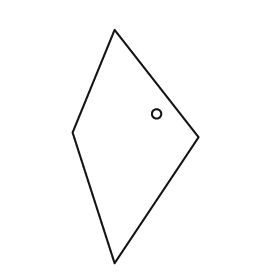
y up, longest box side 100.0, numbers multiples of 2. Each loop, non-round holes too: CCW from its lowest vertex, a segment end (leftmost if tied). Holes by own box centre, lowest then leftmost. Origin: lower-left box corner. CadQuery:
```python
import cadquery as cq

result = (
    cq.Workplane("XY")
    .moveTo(18.0, 0.0)
    .lineTo(54.0, 54.0)
    .lineTo(18.0, 100.0)
    .lineTo(0.0, 56.0)
    .close()
    .moveTo(36.0, 64.0)
    .circle(2.0)
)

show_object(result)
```